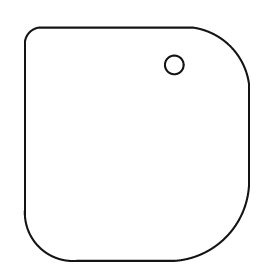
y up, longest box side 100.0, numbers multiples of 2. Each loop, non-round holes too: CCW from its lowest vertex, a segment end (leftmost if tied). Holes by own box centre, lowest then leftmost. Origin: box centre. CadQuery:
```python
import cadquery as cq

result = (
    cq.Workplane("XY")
    .moveTo(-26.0, -50.0)
    .lineTo(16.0, -50.0)
    .threePointArc((38.0, -40.0), (48.0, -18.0))
    .lineTo(48.0, 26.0)
    .threePointArc((40.0, 42.0), (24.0, 50.0))
    .lineTo(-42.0, 50.0)
    .threePointArc((-46.0, 48.0), (-48.0, 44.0))
    .lineTo(-48.0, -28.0)
    .threePointArc((-42.0, -44.0), (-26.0, -50.0))
    .close()
    .moveTo(16.0, 34.0)
    .circle(4.0)
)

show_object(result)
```